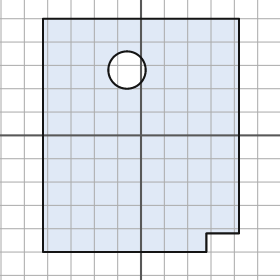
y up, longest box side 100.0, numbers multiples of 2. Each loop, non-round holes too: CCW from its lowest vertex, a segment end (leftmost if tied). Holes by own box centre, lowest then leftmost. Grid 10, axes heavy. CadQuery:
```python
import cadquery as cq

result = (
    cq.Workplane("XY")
    .moveTo(-42.0, -50.0)
    .lineTo(28.0, -50.0)
    .lineTo(28.0, -42.0)
    .lineTo(42.0, -42.0)
    .lineTo(42.0, 50.0)
    .lineTo(-42.0, 50.0)
    .close()
    .moveTo(-6.0, 28.0)
    .circle(8.0)
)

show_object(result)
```